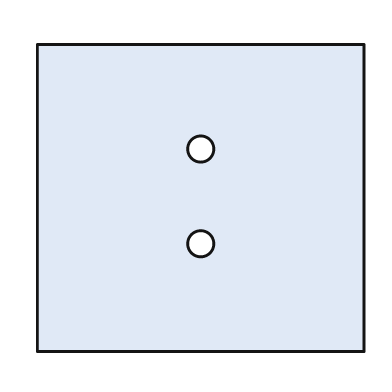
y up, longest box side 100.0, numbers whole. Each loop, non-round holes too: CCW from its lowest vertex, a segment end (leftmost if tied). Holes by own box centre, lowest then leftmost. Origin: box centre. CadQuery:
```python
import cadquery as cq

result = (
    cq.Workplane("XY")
    .moveTo(-50.0, -47.0)
    .lineTo(50.0, -47.0)
    .lineTo(50.0, 47.0)
    .lineTo(-50.0, 47.0)
    .close()
    .moveTo(0.0, -14.0)
    .circle(4.0)
    .moveTo(0.0, 15.0)
    .circle(4.0)
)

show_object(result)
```